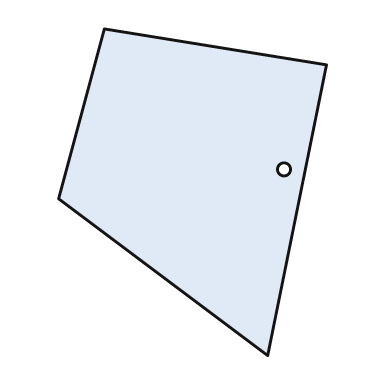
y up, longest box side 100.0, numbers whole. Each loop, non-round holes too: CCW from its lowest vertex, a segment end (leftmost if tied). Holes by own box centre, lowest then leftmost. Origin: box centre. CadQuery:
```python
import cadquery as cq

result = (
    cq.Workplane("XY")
    .moveTo(23.0, -50.0)
    .lineTo(41.0, 39.0)
    .lineTo(-27.0, 50.0)
    .lineTo(-41.0, -2.0)
    .close()
    .moveTo(28.0, 7.0)
    .circle(2.0)
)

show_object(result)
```